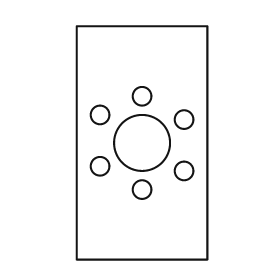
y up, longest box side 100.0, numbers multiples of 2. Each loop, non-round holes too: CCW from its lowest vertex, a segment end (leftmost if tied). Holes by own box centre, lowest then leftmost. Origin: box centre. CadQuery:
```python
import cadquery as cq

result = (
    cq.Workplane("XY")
    .moveTo(-28.0, -50.0)
    .lineTo(28.0, -50.0)
    .lineTo(28.0, 50.0)
    .lineTo(-28.0, 50.0)
    .close()
    .moveTo(0.0, -20.0)
    .circle(4.0)
    .moveTo(18.0, -12.0)
    .circle(4.0)
    .moveTo(-18.0, -10.0)
    .circle(4.0)
    .moveTo(0.0, 0.0)
    .circle(12.0)
    .moveTo(18.0, 10.0)
    .circle(4.0)
    .moveTo(-18.0, 12.0)
    .circle(4.0)
    .moveTo(0.0, 20.0)
    .circle(4.0)
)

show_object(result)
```